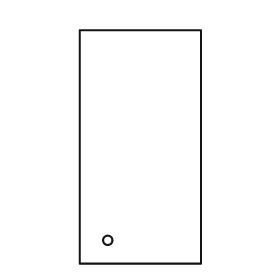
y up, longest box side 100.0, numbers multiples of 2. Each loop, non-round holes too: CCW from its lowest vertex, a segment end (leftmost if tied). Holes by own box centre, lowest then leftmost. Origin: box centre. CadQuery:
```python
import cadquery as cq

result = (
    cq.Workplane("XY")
    .moveTo(-26.0, -50.0)
    .lineTo(26.0, -50.0)
    .lineTo(26.0, 50.0)
    .lineTo(-26.0, 50.0)
    .close()
    .moveTo(-14.0, -40.0)
    .circle(2.0)
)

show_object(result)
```